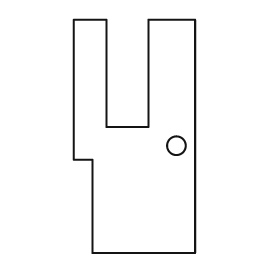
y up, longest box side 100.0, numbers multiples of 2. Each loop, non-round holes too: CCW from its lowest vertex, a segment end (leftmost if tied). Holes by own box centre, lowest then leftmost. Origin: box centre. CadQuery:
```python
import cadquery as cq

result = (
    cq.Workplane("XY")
    .moveTo(-18.0, -50.0)
    .lineTo(26.0, -50.0)
    .lineTo(26.0, 50.0)
    .lineTo(6.0, 50.0)
    .lineTo(6.0, 4.0)
    .lineTo(-12.0, 4.0)
    .lineTo(-12.0, 50.0)
    .lineTo(-26.0, 50.0)
    .lineTo(-26.0, -10.0)
    .lineTo(-18.0, -10.0)
    .close()
    .moveTo(18.0, -4.0)
    .circle(4.0)
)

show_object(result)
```